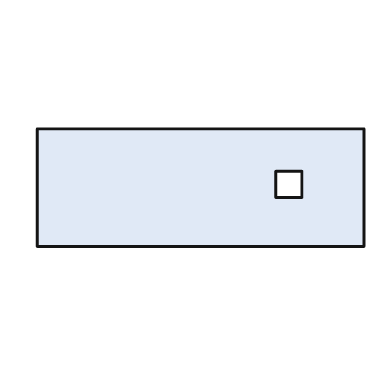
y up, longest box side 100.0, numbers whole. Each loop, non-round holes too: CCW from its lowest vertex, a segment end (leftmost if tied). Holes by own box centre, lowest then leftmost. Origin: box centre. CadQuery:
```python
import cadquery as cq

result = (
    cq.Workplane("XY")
    .moveTo(-50.0, -18.0)
    .lineTo(50.0, -18.0)
    .lineTo(50.0, 18.0)
    .lineTo(-50.0, 18.0)
    .close()
    .moveTo(23.0, -3.0)
    .lineTo(31.0, -3.0)
    .lineTo(31.0, 5.0)
    .lineTo(23.0, 5.0)
    .close()
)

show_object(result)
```